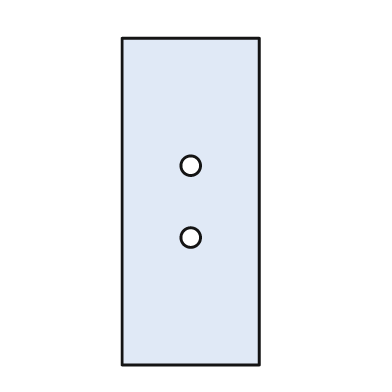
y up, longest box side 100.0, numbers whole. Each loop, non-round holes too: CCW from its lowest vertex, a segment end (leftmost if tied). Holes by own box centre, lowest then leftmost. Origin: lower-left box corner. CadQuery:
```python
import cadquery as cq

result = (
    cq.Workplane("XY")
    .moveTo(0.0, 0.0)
    .lineTo(42.0, 0.0)
    .lineTo(42.0, 100.0)
    .lineTo(0.0, 100.0)
    .close()
    .moveTo(21.0, 39.0)
    .circle(3.0)
    .moveTo(21.0, 61.0)
    .circle(3.0)
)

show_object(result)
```